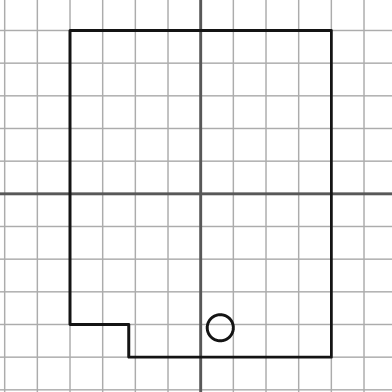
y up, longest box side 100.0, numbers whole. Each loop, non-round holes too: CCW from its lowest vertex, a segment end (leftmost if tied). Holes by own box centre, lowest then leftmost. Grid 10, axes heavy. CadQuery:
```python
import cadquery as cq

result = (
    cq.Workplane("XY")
    .moveTo(-22.0, -50.0)
    .lineTo(40.0, -50.0)
    .lineTo(40.0, 50.0)
    .lineTo(-40.0, 50.0)
    .lineTo(-40.0, -40.0)
    .lineTo(-22.0, -40.0)
    .close()
    .moveTo(6.0, -41.0)
    .circle(4.0)
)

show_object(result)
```